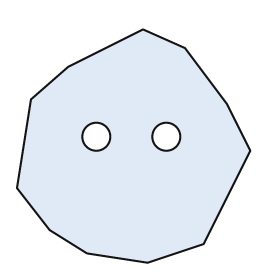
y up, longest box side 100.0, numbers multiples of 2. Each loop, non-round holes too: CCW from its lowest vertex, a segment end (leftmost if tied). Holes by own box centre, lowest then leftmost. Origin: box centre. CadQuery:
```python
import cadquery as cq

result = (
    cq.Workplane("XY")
    .moveTo(6.0, -50.0)
    .lineTo(30.0, -42.0)
    .lineTo(50.0, -2.0)
    .lineTo(40.0, 18.0)
    .lineTo(22.0, 42.0)
    .lineTo(4.0, 50.0)
    .lineTo(-28.0, 34.0)
    .lineTo(-44.0, 20.0)
    .lineTo(-50.0, -18.0)
    .lineTo(-36.0, -36.0)
    .lineTo(-20.0, -46.0)
    .close()
    .moveTo(-16.0, 4.0)
    .circle(6.0)
    .moveTo(14.0, 4.0)
    .circle(6.0)
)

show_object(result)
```